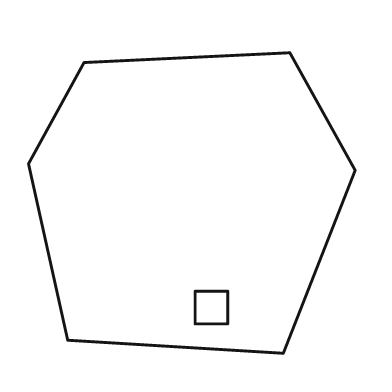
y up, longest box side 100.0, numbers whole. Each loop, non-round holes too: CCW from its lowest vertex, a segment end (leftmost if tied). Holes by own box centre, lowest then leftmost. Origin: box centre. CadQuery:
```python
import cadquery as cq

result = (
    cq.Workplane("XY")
    .moveTo(28.0, -46.0)
    .lineTo(50.0, 10.0)
    .lineTo(30.0, 46.0)
    .lineTo(-33.0, 43.0)
    .lineTo(-50.0, 12.0)
    .lineTo(-38.0, -42.0)
    .close()
    .moveTo(1.0, -37.0)
    .lineTo(11.0, -37.0)
    .lineTo(11.0, -27.0)
    .lineTo(1.0, -27.0)
    .close()
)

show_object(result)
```